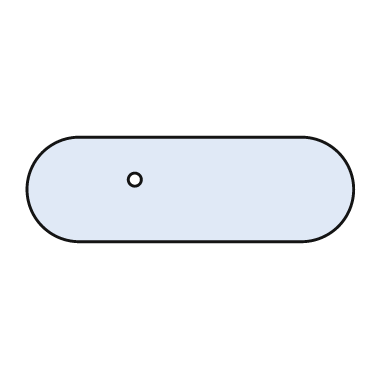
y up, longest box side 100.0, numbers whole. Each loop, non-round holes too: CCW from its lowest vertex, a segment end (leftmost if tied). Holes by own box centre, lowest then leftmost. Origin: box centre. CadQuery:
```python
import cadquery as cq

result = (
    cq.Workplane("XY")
    .moveTo(-34.0, -16.0)
    .lineTo(34.0, -16.0)
    .threePointArc((50.0, 0.0), (34.0, 16.0))
    .lineTo(-34.0, 16.0)
    .threePointArc((-50.0, 0.0), (-34.0, -16.0))
    .close()
    .moveTo(-17.0, 3.0)
    .circle(2.0)
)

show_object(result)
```